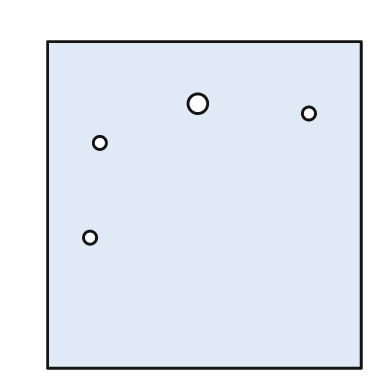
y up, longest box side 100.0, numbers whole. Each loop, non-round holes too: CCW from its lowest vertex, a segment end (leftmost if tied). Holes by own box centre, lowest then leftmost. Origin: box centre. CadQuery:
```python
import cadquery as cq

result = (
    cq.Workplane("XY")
    .moveTo(-48.0, -50.0)
    .lineTo(48.0, -50.0)
    .lineTo(48.0, 50.0)
    .lineTo(-48.0, 50.0)
    .close()
    .moveTo(-35.0, -10.0)
    .circle(2.0)
    .moveTo(-32.0, 19.0)
    .circle(2.0)
    .moveTo(32.0, 28.0)
    .circle(2.0)
    .moveTo(-2.0, 31.0)
    .circle(3.0)
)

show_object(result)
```